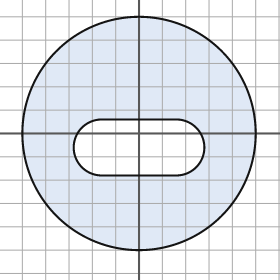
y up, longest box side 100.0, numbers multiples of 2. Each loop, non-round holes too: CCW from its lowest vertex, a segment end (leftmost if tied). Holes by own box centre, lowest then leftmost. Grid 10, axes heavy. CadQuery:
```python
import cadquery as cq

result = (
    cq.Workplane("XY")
    .moveTo(0.0, 0.0)
    .circle(50.0)
    .moveTo(-16.0, -18.0)
    .lineTo(16.0, -18.0)
    .threePointArc((28.0, -6.0), (16.0, 6.0))
    .lineTo(-16.0, 6.0)
    .threePointArc((-28.0, -6.0), (-16.0, -18.0))
    .close()
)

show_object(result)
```